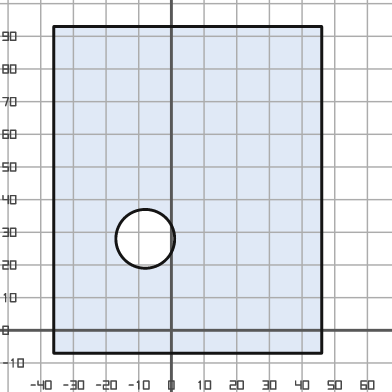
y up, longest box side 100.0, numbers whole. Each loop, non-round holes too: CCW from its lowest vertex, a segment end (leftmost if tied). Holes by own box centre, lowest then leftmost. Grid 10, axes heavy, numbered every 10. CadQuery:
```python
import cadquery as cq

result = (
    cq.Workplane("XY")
    .moveTo(-36.0, -7.0)
    .lineTo(46.0, -7.0)
    .lineTo(46.0, 93.0)
    .lineTo(-36.0, 93.0)
    .close()
    .moveTo(-8.0, 28.0)
    .circle(9.0)
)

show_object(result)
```